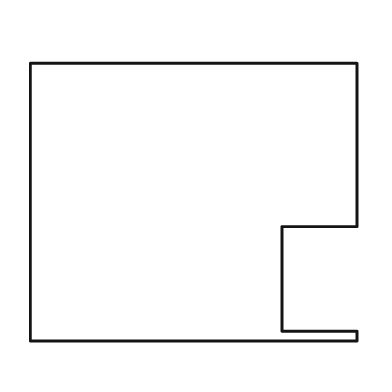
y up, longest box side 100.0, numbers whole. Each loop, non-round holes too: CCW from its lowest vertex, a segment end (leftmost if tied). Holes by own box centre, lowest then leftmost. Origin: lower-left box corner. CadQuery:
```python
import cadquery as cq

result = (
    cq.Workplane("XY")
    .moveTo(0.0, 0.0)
    .lineTo(100.0, 0.0)
    .lineTo(100.0, 3.0)
    .lineTo(77.0, 3.0)
    .lineTo(77.0, 35.0)
    .lineTo(100.0, 35.0)
    .lineTo(100.0, 85.0)
    .lineTo(0.0, 85.0)
    .close()
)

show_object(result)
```